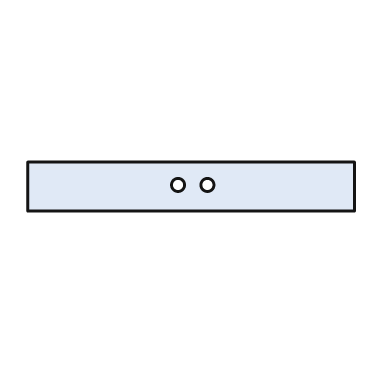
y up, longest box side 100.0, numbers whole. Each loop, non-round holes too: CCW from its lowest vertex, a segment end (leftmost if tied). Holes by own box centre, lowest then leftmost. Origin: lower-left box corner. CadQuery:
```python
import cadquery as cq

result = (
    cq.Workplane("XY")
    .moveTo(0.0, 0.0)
    .lineTo(100.0, 0.0)
    .lineTo(100.0, 15.0)
    .lineTo(0.0, 15.0)
    .close()
    .moveTo(46.0, 8.0)
    .circle(2.0)
    .moveTo(55.0, 8.0)
    .circle(2.0)
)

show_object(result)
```